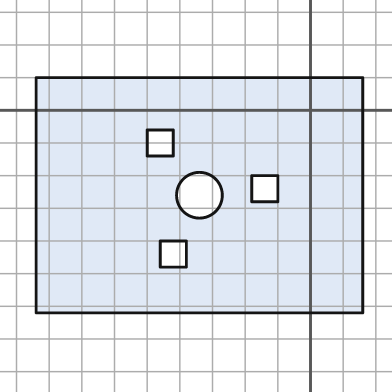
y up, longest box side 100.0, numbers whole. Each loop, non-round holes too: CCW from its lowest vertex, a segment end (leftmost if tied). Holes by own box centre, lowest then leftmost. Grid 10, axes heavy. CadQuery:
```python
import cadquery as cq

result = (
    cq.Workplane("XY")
    .moveTo(-84.0, -62.0)
    .lineTo(16.0, -62.0)
    .lineTo(16.0, 10.0)
    .lineTo(-84.0, 10.0)
    .close()
    .moveTo(-46.0, -48.0)
    .lineTo(-38.0, -48.0)
    .lineTo(-38.0, -40.0)
    .lineTo(-46.0, -40.0)
    .close()
    .moveTo(-34.0, -26.0)
    .circle(7.0)
    .moveTo(-18.0, -28.0)
    .lineTo(-10.0, -28.0)
    .lineTo(-10.0, -20.0)
    .lineTo(-18.0, -20.0)
    .close()
    .moveTo(-50.0, -14.0)
    .lineTo(-42.0, -14.0)
    .lineTo(-42.0, -6.0)
    .lineTo(-50.0, -6.0)
    .close()
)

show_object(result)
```